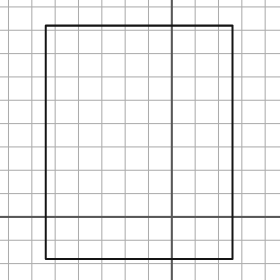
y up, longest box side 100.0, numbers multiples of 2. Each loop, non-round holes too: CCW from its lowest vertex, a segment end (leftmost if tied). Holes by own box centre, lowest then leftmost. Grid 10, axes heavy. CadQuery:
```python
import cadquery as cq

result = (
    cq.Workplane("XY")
    .moveTo(-54.0, -18.0)
    .lineTo(26.0, -18.0)
    .lineTo(26.0, 82.0)
    .lineTo(-54.0, 82.0)
    .close()
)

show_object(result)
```